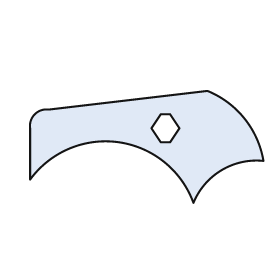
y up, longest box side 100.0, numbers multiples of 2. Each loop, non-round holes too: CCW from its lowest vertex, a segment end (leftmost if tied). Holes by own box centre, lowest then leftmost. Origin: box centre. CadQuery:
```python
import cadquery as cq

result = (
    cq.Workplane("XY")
    .moveTo(20.0, -24.0)
    .threePointArc((32.0, -10.0), (50.0, -6.0))
    .threePointArc((42.0, 12.0), (26.0, 24.0))
    .lineTo(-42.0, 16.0)
    .threePointArc((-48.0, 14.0), (-50.0, 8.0))
    .lineTo(-50.0, -14.0)
    .threePointArc((-12.0, 2.0), (20.0, -24.0))
    .close()
    .moveTo(6.0, 2.0)
    .lineTo(10.0, 2.0)
    .lineTo(14.0, 8.0)
    .lineTo(10.0, 14.0)
    .lineTo(6.0, 14.0)
    .lineTo(2.0, 8.0)
    .close()
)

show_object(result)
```